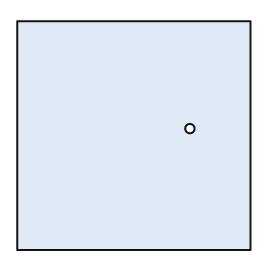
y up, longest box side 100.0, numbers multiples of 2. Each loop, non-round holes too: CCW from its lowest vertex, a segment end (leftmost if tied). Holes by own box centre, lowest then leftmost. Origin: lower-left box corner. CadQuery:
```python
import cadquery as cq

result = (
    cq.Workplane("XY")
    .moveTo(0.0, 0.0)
    .lineTo(100.0, 0.0)
    .lineTo(100.0, 98.0)
    .lineTo(0.0, 98.0)
    .close()
    .moveTo(74.0, 52.0)
    .circle(2.0)
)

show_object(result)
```